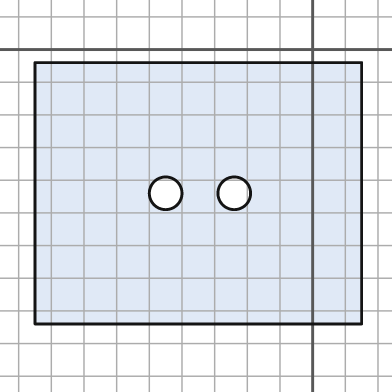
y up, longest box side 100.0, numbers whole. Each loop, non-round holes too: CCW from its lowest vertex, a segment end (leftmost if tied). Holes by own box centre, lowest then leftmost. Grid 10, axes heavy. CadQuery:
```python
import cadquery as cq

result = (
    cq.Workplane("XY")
    .moveTo(-85.0, -84.0)
    .lineTo(15.0, -84.0)
    .lineTo(15.0, -4.0)
    .lineTo(-85.0, -4.0)
    .close()
    .moveTo(-45.0, -44.0)
    .circle(5.0)
    .moveTo(-24.0, -44.0)
    .circle(5.0)
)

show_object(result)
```